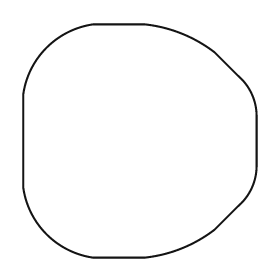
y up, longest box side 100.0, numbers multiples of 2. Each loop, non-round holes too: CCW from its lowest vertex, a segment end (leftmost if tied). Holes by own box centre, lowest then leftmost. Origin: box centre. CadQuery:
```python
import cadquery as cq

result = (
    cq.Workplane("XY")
    .moveTo(-20.0, -50.0)
    .lineTo(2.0, -50.0)
    .threePointArc((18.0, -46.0), (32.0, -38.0))
    .lineTo(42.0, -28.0)
    .threePointArc((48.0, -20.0), (50.0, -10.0))
    .lineTo(50.0, 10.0)
    .threePointArc((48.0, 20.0), (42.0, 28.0))
    .lineTo(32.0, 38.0)
    .threePointArc((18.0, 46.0), (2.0, 50.0))
    .lineTo(-20.0, 50.0)
    .threePointArc((-40.0, 40.0), (-50.0, 20.0))
    .lineTo(-50.0, -20.0)
    .threePointArc((-40.0, -40.0), (-20.0, -50.0))
    .close()
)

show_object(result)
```